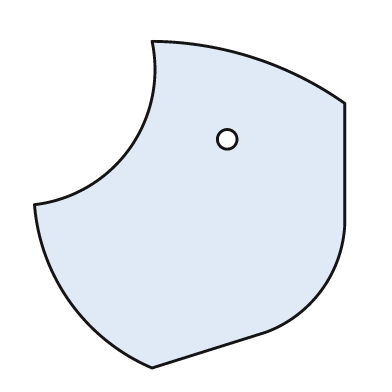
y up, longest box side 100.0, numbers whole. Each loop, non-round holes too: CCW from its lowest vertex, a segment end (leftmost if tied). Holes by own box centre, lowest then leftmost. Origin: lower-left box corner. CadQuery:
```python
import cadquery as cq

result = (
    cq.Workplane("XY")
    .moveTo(36.0, 0.0)
    .lineTo(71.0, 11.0)
    .threePointArc((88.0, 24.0), (95.0, 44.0))
    .lineTo(95.0, 81.0)
    .threePointArc((67.0, 95.0), (36.0, 100.0))
    .threePointArc((29.0, 67.0), (0.0, 50.0))
    .threePointArc((11.0, 20.0), (36.0, 0.0))
    .close()
    .moveTo(59.0, 70.0)
    .circle(3.0)
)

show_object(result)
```